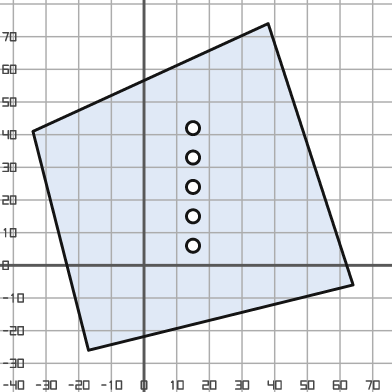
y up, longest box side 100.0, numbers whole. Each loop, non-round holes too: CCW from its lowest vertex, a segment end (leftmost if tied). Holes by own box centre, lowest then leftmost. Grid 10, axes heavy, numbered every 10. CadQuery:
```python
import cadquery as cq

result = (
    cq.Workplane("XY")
    .moveTo(-17.0, -26.0)
    .lineTo(64.0, -6.0)
    .lineTo(38.0, 74.0)
    .lineTo(-34.0, 41.0)
    .close()
    .moveTo(15.0, 6.0)
    .circle(2.0)
    .moveTo(15.0, 15.0)
    .circle(2.0)
    .moveTo(15.0, 24.0)
    .circle(2.0)
    .moveTo(15.0, 33.0)
    .circle(2.0)
    .moveTo(15.0, 42.0)
    .circle(2.0)
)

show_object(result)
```